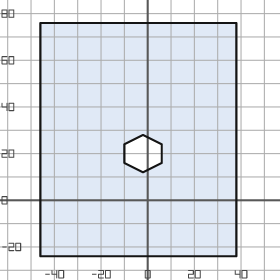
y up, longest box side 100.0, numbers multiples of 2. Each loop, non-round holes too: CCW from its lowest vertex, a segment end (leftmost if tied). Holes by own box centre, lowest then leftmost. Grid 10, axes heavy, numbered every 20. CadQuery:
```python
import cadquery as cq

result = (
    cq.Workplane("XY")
    .moveTo(-46.0, -24.0)
    .lineTo(38.0, -24.0)
    .lineTo(38.0, 76.0)
    .lineTo(-46.0, 76.0)
    .close()
    .moveTo(-2.0, 12.0)
    .lineTo(6.0, 16.0)
    .lineTo(6.0, 24.0)
    .lineTo(-2.0, 28.0)
    .lineTo(-10.0, 24.0)
    .lineTo(-10.0, 16.0)
    .close()
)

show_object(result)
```